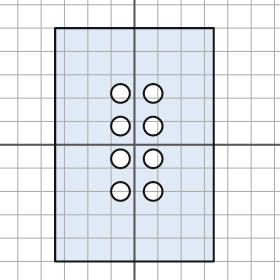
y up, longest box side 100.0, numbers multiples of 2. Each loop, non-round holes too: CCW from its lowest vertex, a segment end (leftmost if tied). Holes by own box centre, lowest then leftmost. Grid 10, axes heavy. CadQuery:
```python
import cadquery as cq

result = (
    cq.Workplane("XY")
    .moveTo(-34.0, -50.0)
    .lineTo(34.0, -50.0)
    .lineTo(34.0, 50.0)
    .lineTo(-34.0, 50.0)
    .close()
    .moveTo(-6.0, -20.0)
    .circle(4.0)
    .moveTo(8.0, -20.0)
    .circle(4.0)
    .moveTo(-6.0, -6.0)
    .circle(4.0)
    .moveTo(8.0, -6.0)
    .circle(4.0)
    .moveTo(-6.0, 8.0)
    .circle(4.0)
    .moveTo(8.0, 8.0)
    .circle(4.0)
    .moveTo(-6.0, 22.0)
    .circle(4.0)
    .moveTo(8.0, 22.0)
    .circle(4.0)
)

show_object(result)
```